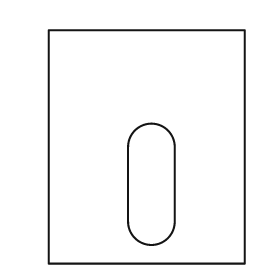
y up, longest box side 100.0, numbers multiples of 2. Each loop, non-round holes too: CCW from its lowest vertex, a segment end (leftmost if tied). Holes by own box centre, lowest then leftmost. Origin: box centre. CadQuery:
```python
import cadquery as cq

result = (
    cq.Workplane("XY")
    .moveTo(-42.0, -50.0)
    .lineTo(42.0, -50.0)
    .lineTo(42.0, 50.0)
    .lineTo(-42.0, 50.0)
    .close()
    .moveTo(-8.0, -32.0)
    .threePointArc((2.0, -42.0), (12.0, -32.0))
    .lineTo(12.0, 0.0)
    .threePointArc((2.0, 10.0), (-8.0, 0.0))
    .close()
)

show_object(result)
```